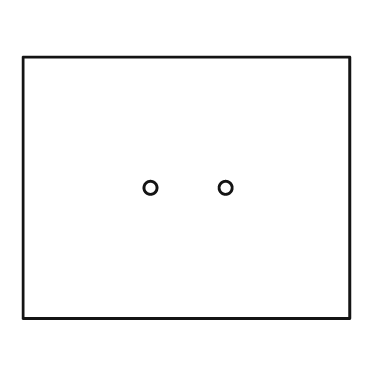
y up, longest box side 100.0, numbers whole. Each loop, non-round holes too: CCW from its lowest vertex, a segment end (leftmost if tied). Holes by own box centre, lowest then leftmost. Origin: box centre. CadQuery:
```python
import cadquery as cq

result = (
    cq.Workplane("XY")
    .moveTo(-50.0, -40.0)
    .lineTo(50.0, -40.0)
    .lineTo(50.0, 40.0)
    .lineTo(-50.0, 40.0)
    .close()
    .moveTo(-11.0, 0.0)
    .circle(2.0)
    .moveTo(12.0, 0.0)
    .circle(2.0)
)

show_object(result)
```